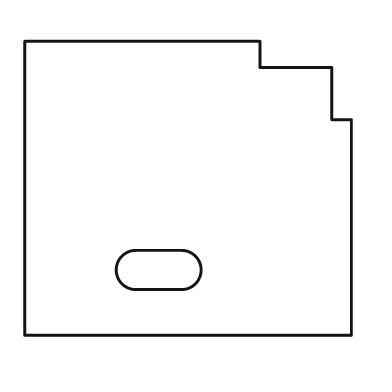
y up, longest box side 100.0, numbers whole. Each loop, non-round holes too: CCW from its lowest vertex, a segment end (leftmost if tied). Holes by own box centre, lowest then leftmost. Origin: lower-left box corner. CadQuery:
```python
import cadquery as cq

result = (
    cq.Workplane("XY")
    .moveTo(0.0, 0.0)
    .lineTo(100.0, 0.0)
    .lineTo(100.0, 66.0)
    .lineTo(94.0, 66.0)
    .lineTo(94.0, 82.0)
    .lineTo(72.0, 82.0)
    .lineTo(72.0, 90.0)
    .lineTo(0.0, 90.0)
    .close()
    .moveTo(34.0, 14.0)
    .lineTo(48.0, 14.0)
    .threePointArc((54.0, 20.0), (48.0, 26.0))
    .lineTo(34.0, 26.0)
    .threePointArc((28.0, 20.0), (34.0, 14.0))
    .close()
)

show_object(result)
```